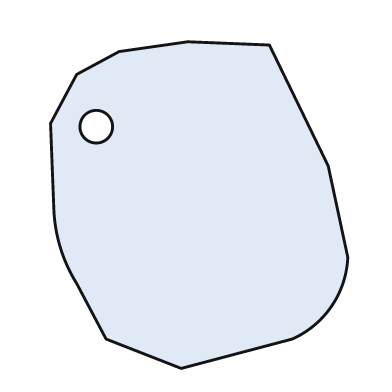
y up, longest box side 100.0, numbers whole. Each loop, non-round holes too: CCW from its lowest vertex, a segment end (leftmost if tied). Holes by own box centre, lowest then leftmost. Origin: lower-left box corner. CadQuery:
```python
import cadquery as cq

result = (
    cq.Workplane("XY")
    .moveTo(40.0, 0.0)
    .lineTo(74.0, 9.0)
    .threePointArc((86.0, 19.0), (91.0, 34.0))
    .lineTo(85.0, 62.0)
    .lineTo(67.0, 99.0)
    .lineTo(42.0, 100.0)
    .lineTo(21.0, 97.0)
    .lineTo(8.0, 90.0)
    .lineTo(0.0, 75.0)
    .lineTo(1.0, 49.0)
    .threePointArc((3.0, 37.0), (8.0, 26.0))
    .lineTo(17.0, 9.0)
    .close()
    .moveTo(14.0, 74.0)
    .circle(5.0)
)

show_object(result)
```